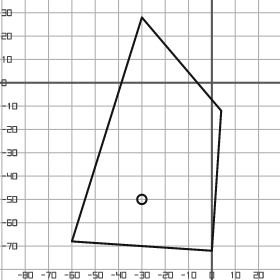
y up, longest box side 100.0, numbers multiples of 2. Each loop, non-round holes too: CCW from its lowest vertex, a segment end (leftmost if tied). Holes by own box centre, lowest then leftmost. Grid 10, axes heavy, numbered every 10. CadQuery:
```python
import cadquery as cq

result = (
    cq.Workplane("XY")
    .moveTo(0.0, -72.0)
    .lineTo(4.0, -12.0)
    .lineTo(-30.0, 28.0)
    .lineTo(-60.0, -68.0)
    .close()
    .moveTo(-30.0, -50.0)
    .circle(2.0)
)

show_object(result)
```